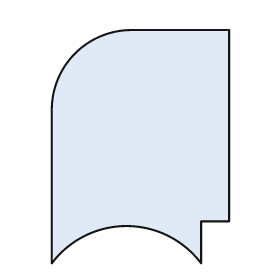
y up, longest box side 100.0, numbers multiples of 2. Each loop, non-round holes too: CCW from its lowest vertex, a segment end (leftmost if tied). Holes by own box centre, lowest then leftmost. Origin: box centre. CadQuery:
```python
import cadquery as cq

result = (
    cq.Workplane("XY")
    .moveTo(-38.0, -50.0)
    .threePointArc((-6.0, -34.0), (26.0, -50.0))
    .lineTo(26.0, -32.0)
    .lineTo(38.0, -32.0)
    .lineTo(38.0, 50.0)
    .lineTo(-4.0, 50.0)
    .threePointArc((-28.0, 40.0), (-38.0, 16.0))
    .close()
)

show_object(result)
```